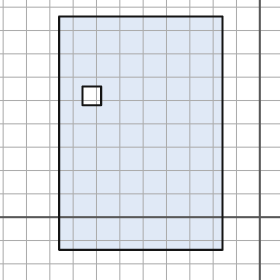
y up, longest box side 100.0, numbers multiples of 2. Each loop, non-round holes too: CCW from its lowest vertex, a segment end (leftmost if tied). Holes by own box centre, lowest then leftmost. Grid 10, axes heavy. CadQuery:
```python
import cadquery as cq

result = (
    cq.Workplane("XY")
    .moveTo(-86.0, -14.0)
    .lineTo(-16.0, -14.0)
    .lineTo(-16.0, 86.0)
    .lineTo(-86.0, 86.0)
    .close()
    .moveTo(-76.0, 48.0)
    .lineTo(-68.0, 48.0)
    .lineTo(-68.0, 56.0)
    .lineTo(-76.0, 56.0)
    .close()
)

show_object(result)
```